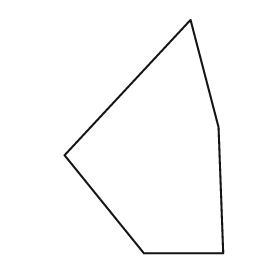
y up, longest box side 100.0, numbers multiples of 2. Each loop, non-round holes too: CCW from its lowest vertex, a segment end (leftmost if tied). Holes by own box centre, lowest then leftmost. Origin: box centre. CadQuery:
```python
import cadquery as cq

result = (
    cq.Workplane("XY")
    .moveTo(0.0, -50.0)
    .lineTo(34.0, -50.0)
    .lineTo(32.0, 4.0)
    .lineTo(20.0, 50.0)
    .lineTo(-34.0, -8.0)
    .close()
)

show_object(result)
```